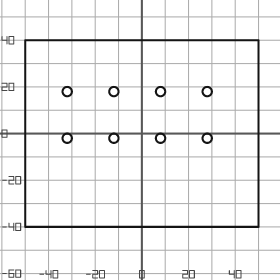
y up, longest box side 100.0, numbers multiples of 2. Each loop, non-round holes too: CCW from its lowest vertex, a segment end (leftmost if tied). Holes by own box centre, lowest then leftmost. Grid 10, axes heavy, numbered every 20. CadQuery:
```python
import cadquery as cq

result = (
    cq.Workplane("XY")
    .moveTo(-50.0, -40.0)
    .lineTo(50.0, -40.0)
    .lineTo(50.0, 40.0)
    .lineTo(-50.0, 40.0)
    .close()
    .moveTo(-32.0, -2.0)
    .circle(2.0)
    .moveTo(-12.0, -2.0)
    .circle(2.0)
    .moveTo(8.0, -2.0)
    .circle(2.0)
    .moveTo(28.0, -2.0)
    .circle(2.0)
    .moveTo(-32.0, 18.0)
    .circle(2.0)
    .moveTo(-12.0, 18.0)
    .circle(2.0)
    .moveTo(8.0, 18.0)
    .circle(2.0)
    .moveTo(28.0, 18.0)
    .circle(2.0)
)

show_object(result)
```